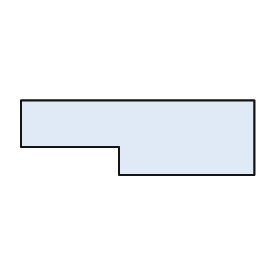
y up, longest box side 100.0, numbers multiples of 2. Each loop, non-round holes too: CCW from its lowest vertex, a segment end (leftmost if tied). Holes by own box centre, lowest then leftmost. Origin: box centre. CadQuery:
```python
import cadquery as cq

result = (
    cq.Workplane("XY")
    .moveTo(-8.0, -16.0)
    .lineTo(50.0, -16.0)
    .lineTo(50.0, 16.0)
    .lineTo(-50.0, 16.0)
    .lineTo(-50.0, -4.0)
    .lineTo(-8.0, -4.0)
    .close()
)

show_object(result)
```